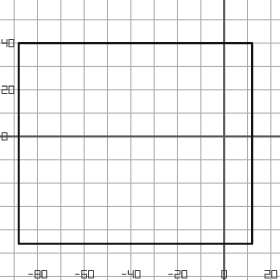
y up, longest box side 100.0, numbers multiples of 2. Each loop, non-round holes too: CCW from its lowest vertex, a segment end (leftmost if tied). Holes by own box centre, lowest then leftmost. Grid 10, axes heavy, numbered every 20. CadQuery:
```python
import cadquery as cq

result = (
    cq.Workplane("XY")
    .moveTo(-88.0, -46.0)
    .lineTo(12.0, -46.0)
    .lineTo(12.0, 40.0)
    .lineTo(-88.0, 40.0)
    .close()
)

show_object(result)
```